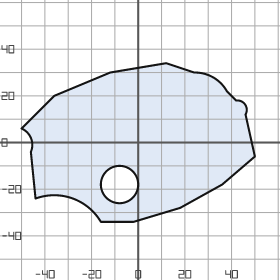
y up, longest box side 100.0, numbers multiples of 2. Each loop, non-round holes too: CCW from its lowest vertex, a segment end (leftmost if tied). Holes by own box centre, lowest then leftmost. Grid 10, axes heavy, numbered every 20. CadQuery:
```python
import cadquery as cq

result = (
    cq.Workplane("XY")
    .moveTo(-16.0, -34.0)
    .lineTo(-2.0, -34.0)
    .lineTo(18.0, -28.0)
    .lineTo(36.0, -18.0)
    .lineTo(50.0, -6.0)
    .lineTo(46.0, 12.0)
    .threePointArc((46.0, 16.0), (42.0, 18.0))
    .lineTo(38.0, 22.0)
    .threePointArc((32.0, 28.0), (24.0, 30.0))
    .lineTo(12.0, 34.0)
    .lineTo(-12.0, 30.0)
    .lineTo(-36.0, 20.0)
    .lineTo(-50.0, 6.0)
    .threePointArc((-46.0, 2.0), (-46.0, -4.0))
    .lineTo(-44.0, -24.0)
    .threePointArc((-28.0, -24.0), (-16.0, -34.0))
    .close()
    .moveTo(-8.0, -18.0)
    .circle(8.0)
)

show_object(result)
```